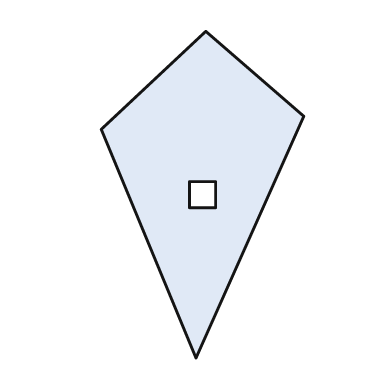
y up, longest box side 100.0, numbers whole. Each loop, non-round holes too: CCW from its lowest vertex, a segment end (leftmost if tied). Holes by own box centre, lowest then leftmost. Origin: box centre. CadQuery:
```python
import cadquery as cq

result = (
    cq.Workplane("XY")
    .moveTo(-2.0, -50.0)
    .lineTo(31.0, 24.0)
    .lineTo(1.0, 50.0)
    .lineTo(-31.0, 20.0)
    .close()
    .moveTo(-4.0, -4.0)
    .lineTo(4.0, -4.0)
    .lineTo(4.0, 4.0)
    .lineTo(-4.0, 4.0)
    .close()
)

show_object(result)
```